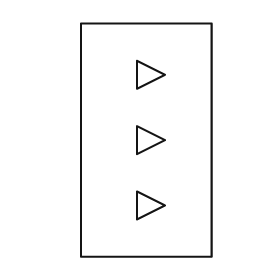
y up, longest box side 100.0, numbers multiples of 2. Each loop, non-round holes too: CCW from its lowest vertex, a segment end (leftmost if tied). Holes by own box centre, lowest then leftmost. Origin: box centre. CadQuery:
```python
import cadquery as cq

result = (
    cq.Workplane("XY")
    .moveTo(-28.0, -50.0)
    .lineTo(28.0, -50.0)
    .lineTo(28.0, 50.0)
    .lineTo(-28.0, 50.0)
    .close()
    .moveTo(-4.0, -34.0)
    .lineTo(8.0, -28.0)
    .lineTo(-4.0, -22.0)
    .close()
    .moveTo(-4.0, -6.0)
    .lineTo(8.0, 0.0)
    .lineTo(-4.0, 6.0)
    .close()
    .moveTo(-4.0, 22.0)
    .lineTo(8.0, 28.0)
    .lineTo(-4.0, 34.0)
    .close()
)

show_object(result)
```